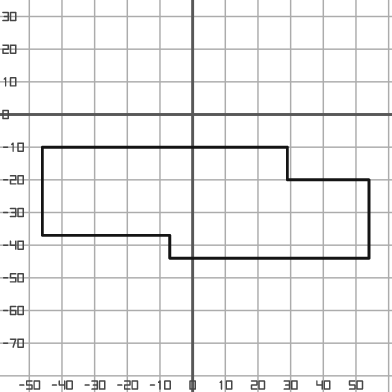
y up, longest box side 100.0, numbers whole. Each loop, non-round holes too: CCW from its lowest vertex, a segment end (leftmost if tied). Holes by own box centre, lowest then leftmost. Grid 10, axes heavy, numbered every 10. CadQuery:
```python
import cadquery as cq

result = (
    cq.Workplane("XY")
    .moveTo(-7.0, -44.0)
    .lineTo(54.0, -44.0)
    .lineTo(54.0, -20.0)
    .lineTo(29.0, -20.0)
    .lineTo(29.0, -10.0)
    .lineTo(-46.0, -10.0)
    .lineTo(-46.0, -37.0)
    .lineTo(-7.0, -37.0)
    .close()
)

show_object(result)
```